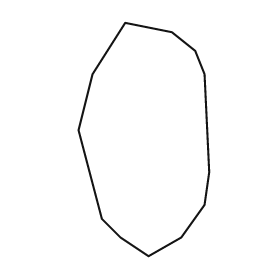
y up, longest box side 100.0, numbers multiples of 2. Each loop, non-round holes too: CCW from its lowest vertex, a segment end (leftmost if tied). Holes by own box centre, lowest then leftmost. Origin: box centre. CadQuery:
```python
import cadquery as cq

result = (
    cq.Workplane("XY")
    .moveTo(2.0, -50.0)
    .lineTo(16.0, -42.0)
    .lineTo(26.0, -28.0)
    .lineTo(28.0, -14.0)
    .lineTo(26.0, 28.0)
    .lineTo(22.0, 38.0)
    .lineTo(12.0, 46.0)
    .lineTo(-8.0, 50.0)
    .lineTo(-22.0, 28.0)
    .lineTo(-28.0, 4.0)
    .lineTo(-18.0, -34.0)
    .lineTo(-10.0, -42.0)
    .close()
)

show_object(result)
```